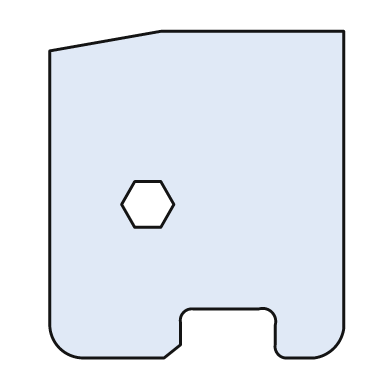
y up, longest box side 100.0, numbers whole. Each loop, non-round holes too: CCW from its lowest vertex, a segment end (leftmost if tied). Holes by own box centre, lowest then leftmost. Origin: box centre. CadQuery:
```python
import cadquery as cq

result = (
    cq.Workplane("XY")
    .moveTo(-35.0, -50.0)
    .lineTo(-10.0, -50.0)
    .lineTo(-5.0, -46.0)
    .lineTo(-5.0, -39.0)
    .threePointArc((-4.0, -36.0), (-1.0, -35.0))
    .lineTo(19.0, -35.0)
    .threePointArc((23.0, -36.0), (24.0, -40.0))
    .lineTo(24.0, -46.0)
    .threePointArc((25.0, -49.0), (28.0, -50.0))
    .lineTo(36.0, -50.0)
    .threePointArc((42.0, -47.0), (45.0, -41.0))
    .lineTo(45.0, 50.0)
    .lineTo(-11.0, 50.0)
    .lineTo(-45.0, 44.0)
    .lineTo(-45.0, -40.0)
    .threePointArc((-42.0, -47.0), (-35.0, -50.0))
    .close()
    .moveTo(-19.0, -10.0)
    .lineTo(-11.0, -10.0)
    .lineTo(-7.0, -3.0)
    .lineTo(-11.0, 4.0)
    .lineTo(-19.0, 4.0)
    .lineTo(-23.0, -3.0)
    .close()
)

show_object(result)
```